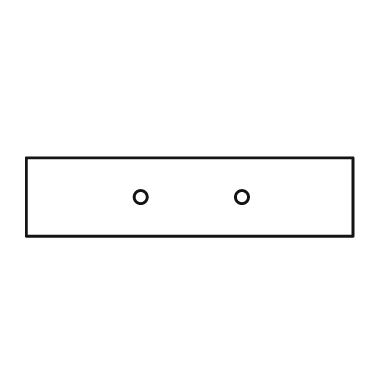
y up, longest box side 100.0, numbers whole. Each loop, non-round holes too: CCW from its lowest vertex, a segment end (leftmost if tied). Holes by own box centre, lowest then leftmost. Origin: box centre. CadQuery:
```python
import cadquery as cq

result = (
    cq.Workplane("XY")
    .moveTo(-50.0, -12.0)
    .lineTo(50.0, -12.0)
    .lineTo(50.0, 12.0)
    .lineTo(-50.0, 12.0)
    .close()
    .moveTo(-15.0, 0.0)
    .circle(2.0)
    .moveTo(16.0, 0.0)
    .circle(2.0)
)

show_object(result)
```